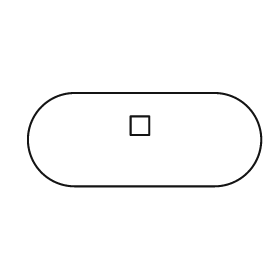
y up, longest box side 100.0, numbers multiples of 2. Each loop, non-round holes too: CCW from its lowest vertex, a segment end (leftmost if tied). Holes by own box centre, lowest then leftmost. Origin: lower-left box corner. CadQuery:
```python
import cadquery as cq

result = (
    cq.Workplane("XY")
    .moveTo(20.0, 0.0)
    .lineTo(80.0, 0.0)
    .threePointArc((100.0, 20.0), (80.0, 40.0))
    .lineTo(20.0, 40.0)
    .threePointArc((0.0, 20.0), (20.0, 0.0))
    .close()
    .moveTo(44.0, 22.0)
    .lineTo(52.0, 22.0)
    .lineTo(52.0, 30.0)
    .lineTo(44.0, 30.0)
    .close()
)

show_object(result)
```